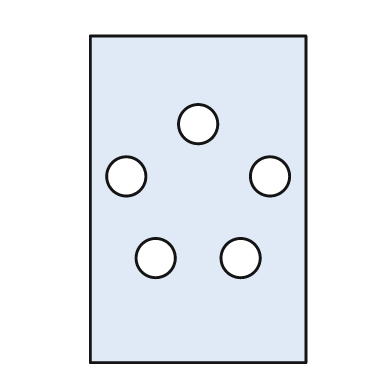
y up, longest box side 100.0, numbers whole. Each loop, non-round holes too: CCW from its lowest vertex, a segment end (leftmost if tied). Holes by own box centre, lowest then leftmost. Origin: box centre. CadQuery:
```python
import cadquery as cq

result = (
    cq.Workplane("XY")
    .moveTo(-33.0, -50.0)
    .lineTo(33.0, -50.0)
    .lineTo(33.0, 50.0)
    .lineTo(-33.0, 50.0)
    .close()
    .moveTo(-13.0, -18.0)
    .circle(6.0)
    .moveTo(13.0, -18.0)
    .circle(6.0)
    .moveTo(-22.0, 7.0)
    .circle(6.0)
    .moveTo(22.0, 7.0)
    .circle(6.0)
    .moveTo(0.0, 23.0)
    .circle(6.0)
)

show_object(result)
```